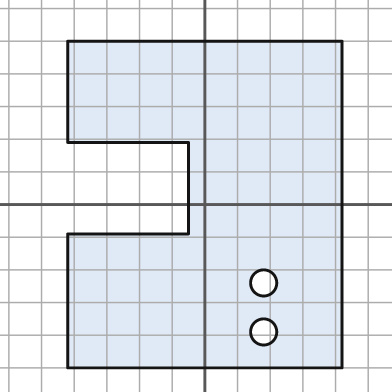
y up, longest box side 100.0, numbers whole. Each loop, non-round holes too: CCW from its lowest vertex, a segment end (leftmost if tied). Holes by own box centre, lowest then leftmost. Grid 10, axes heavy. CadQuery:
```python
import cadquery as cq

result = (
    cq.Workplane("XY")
    .moveTo(-42.0, -50.0)
    .lineTo(42.0, -50.0)
    .lineTo(42.0, 50.0)
    .lineTo(-42.0, 50.0)
    .lineTo(-42.0, 19.0)
    .lineTo(-5.0, 19.0)
    .lineTo(-5.0, -9.0)
    .lineTo(-42.0, -9.0)
    .close()
    .moveTo(18.0, -39.0)
    .circle(4.0)
    .moveTo(18.0, -24.0)
    .circle(4.0)
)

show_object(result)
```